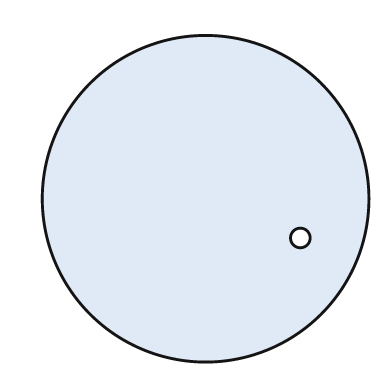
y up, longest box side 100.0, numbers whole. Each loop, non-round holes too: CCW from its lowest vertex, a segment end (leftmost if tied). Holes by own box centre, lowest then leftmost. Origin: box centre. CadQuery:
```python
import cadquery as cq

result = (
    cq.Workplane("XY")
    .moveTo(0.0, 0.0)
    .circle(50.0)
    .moveTo(29.0, -12.0)
    .circle(3.0)
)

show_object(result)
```